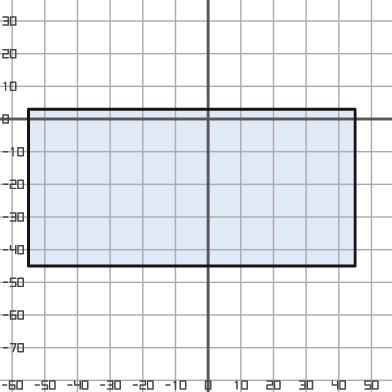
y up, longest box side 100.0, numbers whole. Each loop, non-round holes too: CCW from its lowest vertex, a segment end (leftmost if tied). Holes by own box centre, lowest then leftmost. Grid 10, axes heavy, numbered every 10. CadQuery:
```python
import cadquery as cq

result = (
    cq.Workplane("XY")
    .moveTo(-55.0, -45.0)
    .lineTo(45.0, -45.0)
    .lineTo(45.0, 3.0)
    .lineTo(-55.0, 3.0)
    .close()
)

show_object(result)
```